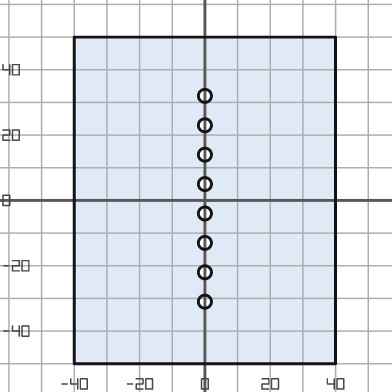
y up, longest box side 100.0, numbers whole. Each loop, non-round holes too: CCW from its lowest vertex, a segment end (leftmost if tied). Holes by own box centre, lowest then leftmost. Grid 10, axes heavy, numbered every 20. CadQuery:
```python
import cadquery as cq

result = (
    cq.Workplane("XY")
    .moveTo(-40.0, -50.0)
    .lineTo(40.0, -50.0)
    .lineTo(40.0, 50.0)
    .lineTo(-40.0, 50.0)
    .close()
    .moveTo(0.0, -31.0)
    .circle(2.0)
    .moveTo(0.0, -22.0)
    .circle(2.0)
    .moveTo(0.0, -13.0)
    .circle(2.0)
    .moveTo(0.0, -4.0)
    .circle(2.0)
    .moveTo(0.0, 5.0)
    .circle(2.0)
    .moveTo(0.0, 14.0)
    .circle(2.0)
    .moveTo(0.0, 23.0)
    .circle(2.0)
    .moveTo(0.0, 32.0)
    .circle(2.0)
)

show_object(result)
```